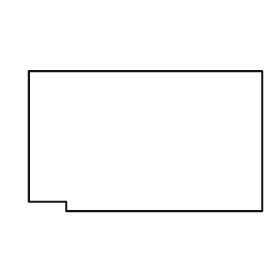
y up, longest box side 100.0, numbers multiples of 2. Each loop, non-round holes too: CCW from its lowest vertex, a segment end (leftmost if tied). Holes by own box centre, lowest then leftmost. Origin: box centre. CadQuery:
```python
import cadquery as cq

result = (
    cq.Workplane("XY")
    .moveTo(-34.0, -30.0)
    .lineTo(50.0, -30.0)
    .lineTo(50.0, 30.0)
    .lineTo(-50.0, 30.0)
    .lineTo(-50.0, -26.0)
    .lineTo(-34.0, -26.0)
    .close()
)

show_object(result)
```